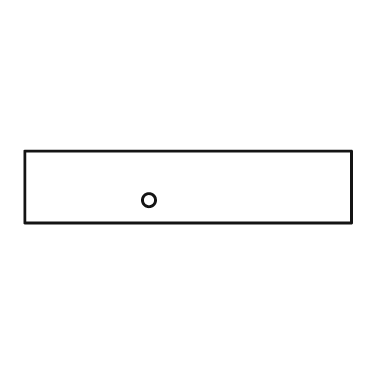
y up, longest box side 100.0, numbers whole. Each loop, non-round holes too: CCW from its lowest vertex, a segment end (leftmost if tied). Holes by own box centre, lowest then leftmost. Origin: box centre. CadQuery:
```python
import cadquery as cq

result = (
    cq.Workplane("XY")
    .moveTo(-50.0, -11.0)
    .lineTo(50.0, -11.0)
    .lineTo(50.0, 11.0)
    .lineTo(-50.0, 11.0)
    .close()
    .moveTo(-12.0, -4.0)
    .circle(2.0)
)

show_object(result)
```